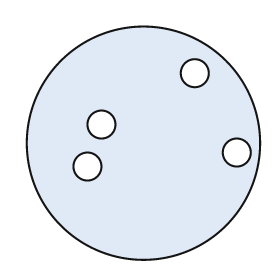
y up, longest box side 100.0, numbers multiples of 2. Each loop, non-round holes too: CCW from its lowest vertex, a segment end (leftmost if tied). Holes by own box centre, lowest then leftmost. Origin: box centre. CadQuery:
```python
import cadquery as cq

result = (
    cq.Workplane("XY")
    .moveTo(0.0, 0.0)
    .circle(50.0)
    .moveTo(-24.0, -10.0)
    .circle(6.0)
    .moveTo(40.0, -4.0)
    .circle(6.0)
    .moveTo(-18.0, 8.0)
    .circle(6.0)
    .moveTo(22.0, 30.0)
    .circle(6.0)
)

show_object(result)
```